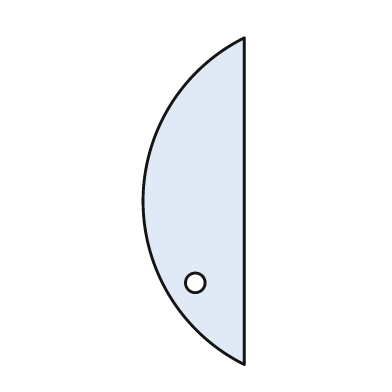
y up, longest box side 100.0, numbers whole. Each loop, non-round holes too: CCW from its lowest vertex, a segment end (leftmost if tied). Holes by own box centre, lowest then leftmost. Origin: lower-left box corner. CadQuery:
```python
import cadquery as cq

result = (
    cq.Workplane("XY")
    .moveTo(31.0, 0.0)
    .lineTo(31.0, 100.0)
    .threePointArc((0.0, 50.0), (31.0, 0.0))
    .close()
    .moveTo(16.0, 25.0)
    .circle(3.0)
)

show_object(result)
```